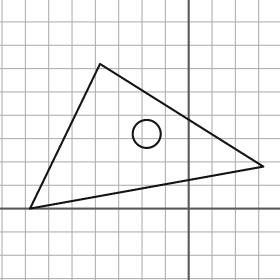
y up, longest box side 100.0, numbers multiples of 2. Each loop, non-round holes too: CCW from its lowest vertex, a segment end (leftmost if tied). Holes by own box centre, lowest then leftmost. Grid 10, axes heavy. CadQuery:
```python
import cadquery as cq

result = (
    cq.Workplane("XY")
    .moveTo(-68.0, 0.0)
    .lineTo(32.0, 18.0)
    .lineTo(-38.0, 62.0)
    .close()
    .moveTo(-18.0, 32.0)
    .circle(6.0)
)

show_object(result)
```